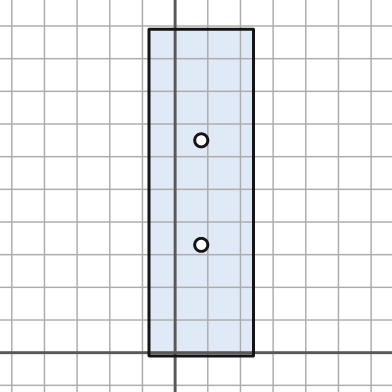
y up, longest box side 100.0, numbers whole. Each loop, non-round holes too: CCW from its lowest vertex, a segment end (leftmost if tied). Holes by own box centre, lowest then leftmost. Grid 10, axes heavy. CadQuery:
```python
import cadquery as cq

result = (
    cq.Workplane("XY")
    .moveTo(-8.0, -1.0)
    .lineTo(24.0, -1.0)
    .lineTo(24.0, 99.0)
    .lineTo(-8.0, 99.0)
    .close()
    .moveTo(8.0, 33.0)
    .circle(2.0)
    .moveTo(8.0, 65.0)
    .circle(2.0)
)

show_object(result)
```